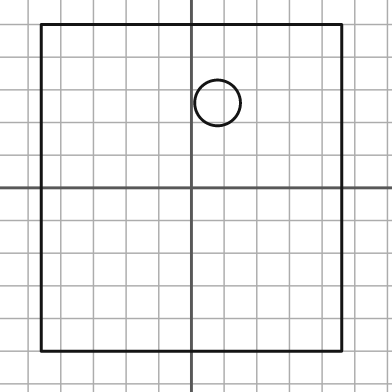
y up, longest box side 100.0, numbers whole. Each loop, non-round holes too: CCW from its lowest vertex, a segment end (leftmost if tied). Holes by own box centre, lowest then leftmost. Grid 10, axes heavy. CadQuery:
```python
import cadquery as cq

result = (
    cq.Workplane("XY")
    .moveTo(-46.0, -50.0)
    .lineTo(46.0, -50.0)
    .lineTo(46.0, 50.0)
    .lineTo(-46.0, 50.0)
    .close()
    .moveTo(8.0, 26.0)
    .circle(7.0)
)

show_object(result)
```